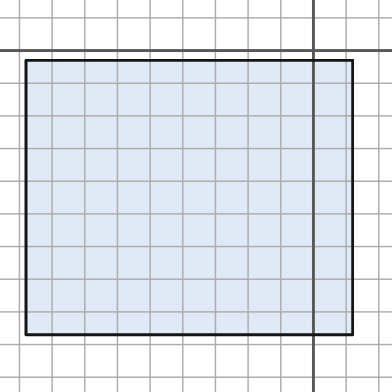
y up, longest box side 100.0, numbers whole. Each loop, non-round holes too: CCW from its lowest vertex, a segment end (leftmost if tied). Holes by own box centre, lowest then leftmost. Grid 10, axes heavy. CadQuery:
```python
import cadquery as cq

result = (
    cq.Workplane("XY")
    .moveTo(-88.0, -87.0)
    .lineTo(12.0, -87.0)
    .lineTo(12.0, -3.0)
    .lineTo(-88.0, -3.0)
    .close()
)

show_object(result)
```